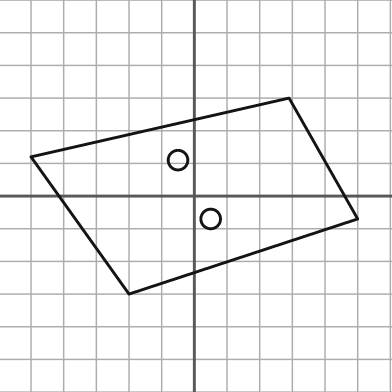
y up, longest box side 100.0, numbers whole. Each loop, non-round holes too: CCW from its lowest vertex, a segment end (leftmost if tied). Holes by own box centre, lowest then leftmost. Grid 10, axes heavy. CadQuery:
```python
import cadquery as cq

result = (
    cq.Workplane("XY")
    .moveTo(-20.0, -30.0)
    .lineTo(50.0, -7.0)
    .lineTo(29.0, 30.0)
    .lineTo(-50.0, 12.0)
    .close()
    .moveTo(5.0, -7.0)
    .circle(3.0)
    .moveTo(-5.0, 11.0)
    .circle(3.0)
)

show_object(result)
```